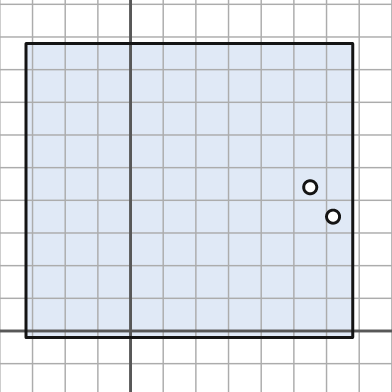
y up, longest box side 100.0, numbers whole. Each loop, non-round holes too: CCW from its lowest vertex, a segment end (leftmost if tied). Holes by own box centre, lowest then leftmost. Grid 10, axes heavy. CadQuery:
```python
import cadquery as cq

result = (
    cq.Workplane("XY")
    .moveTo(-32.0, -2.0)
    .lineTo(68.0, -2.0)
    .lineTo(68.0, 88.0)
    .lineTo(-32.0, 88.0)
    .close()
    .moveTo(62.0, 35.0)
    .circle(2.0)
    .moveTo(55.0, 44.0)
    .circle(2.0)
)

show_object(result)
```